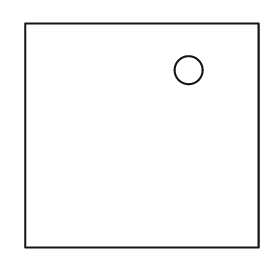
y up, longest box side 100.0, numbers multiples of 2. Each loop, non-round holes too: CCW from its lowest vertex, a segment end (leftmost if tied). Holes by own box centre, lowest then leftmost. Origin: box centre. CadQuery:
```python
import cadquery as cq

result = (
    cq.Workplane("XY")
    .moveTo(-50.0, -48.0)
    .lineTo(50.0, -48.0)
    .lineTo(50.0, 48.0)
    .lineTo(-50.0, 48.0)
    .close()
    .moveTo(20.0, 28.0)
    .circle(6.0)
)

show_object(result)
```